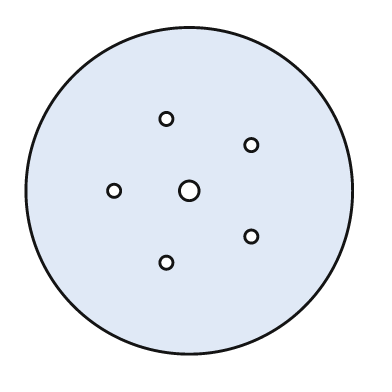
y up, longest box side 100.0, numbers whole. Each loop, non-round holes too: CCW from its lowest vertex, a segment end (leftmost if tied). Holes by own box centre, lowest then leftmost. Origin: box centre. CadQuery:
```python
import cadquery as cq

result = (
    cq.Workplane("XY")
    .moveTo(0.0, 0.0)
    .circle(50.0)
    .moveTo(-7.0, -22.0)
    .circle(2.0)
    .moveTo(19.0, -14.0)
    .circle(2.0)
    .moveTo(-23.0, 0.0)
    .circle(2.0)
    .moveTo(0.0, 0.0)
    .circle(3.0)
    .moveTo(19.0, 14.0)
    .circle(2.0)
    .moveTo(-7.0, 22.0)
    .circle(2.0)
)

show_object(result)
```